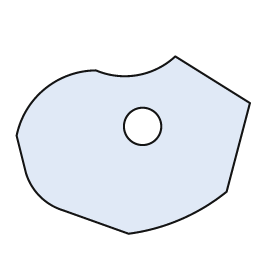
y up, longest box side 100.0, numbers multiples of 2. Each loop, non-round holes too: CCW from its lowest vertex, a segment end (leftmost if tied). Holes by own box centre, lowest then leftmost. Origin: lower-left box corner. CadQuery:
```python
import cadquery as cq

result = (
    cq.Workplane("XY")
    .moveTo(48.0, 0.0)
    .threePointArc((70.0, 6.0), (90.0, 18.0))
    .lineTo(100.0, 56.0)
    .lineTo(68.0, 76.0)
    .threePointArc((52.0, 68.0), (34.0, 70.0))
    .threePointArc((12.0, 62.0), (0.0, 42.0))
    .lineTo(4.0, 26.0)
    .threePointArc((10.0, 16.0), (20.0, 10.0))
    .close()
    .moveTo(54.0, 46.0)
    .circle(8.0)
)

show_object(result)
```